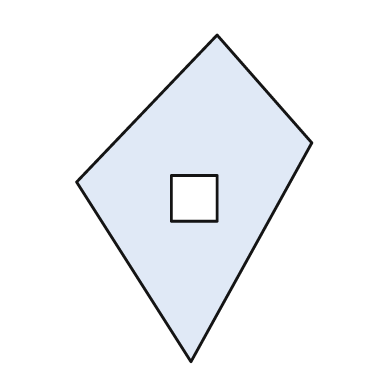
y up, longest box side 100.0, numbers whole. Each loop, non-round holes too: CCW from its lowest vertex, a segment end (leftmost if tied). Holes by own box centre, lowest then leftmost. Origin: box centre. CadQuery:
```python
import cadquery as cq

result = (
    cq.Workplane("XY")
    .moveTo(-1.0, -50.0)
    .lineTo(36.0, 17.0)
    .lineTo(7.0, 50.0)
    .lineTo(-36.0, 5.0)
    .close()
    .moveTo(-7.0, -7.0)
    .lineTo(7.0, -7.0)
    .lineTo(7.0, 7.0)
    .lineTo(-7.0, 7.0)
    .close()
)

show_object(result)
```